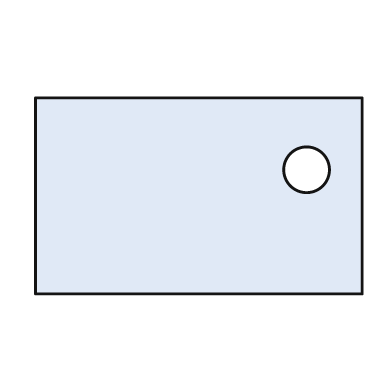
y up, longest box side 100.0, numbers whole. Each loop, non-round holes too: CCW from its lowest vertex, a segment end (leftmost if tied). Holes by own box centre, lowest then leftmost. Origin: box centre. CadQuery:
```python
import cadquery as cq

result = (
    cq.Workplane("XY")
    .moveTo(-50.0, -30.0)
    .lineTo(50.0, -30.0)
    .lineTo(50.0, 30.0)
    .lineTo(-50.0, 30.0)
    .close()
    .moveTo(33.0, 8.0)
    .circle(7.0)
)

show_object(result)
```